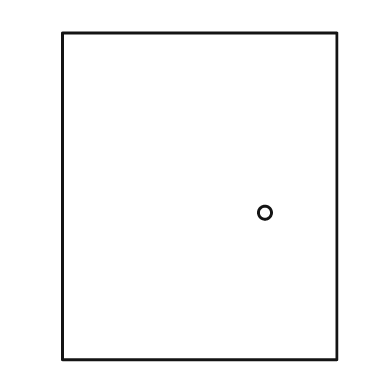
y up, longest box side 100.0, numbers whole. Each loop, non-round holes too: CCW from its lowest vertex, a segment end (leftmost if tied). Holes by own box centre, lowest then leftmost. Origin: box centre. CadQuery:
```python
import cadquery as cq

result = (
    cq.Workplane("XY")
    .moveTo(-42.0, -50.0)
    .lineTo(42.0, -50.0)
    .lineTo(42.0, 50.0)
    .lineTo(-42.0, 50.0)
    .close()
    .moveTo(20.0, -5.0)
    .circle(2.0)
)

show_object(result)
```